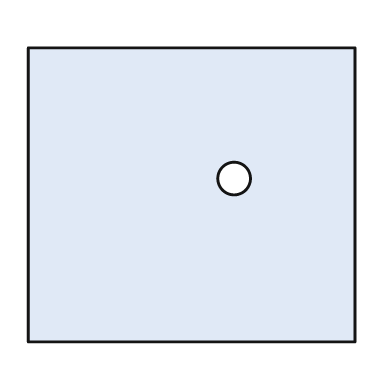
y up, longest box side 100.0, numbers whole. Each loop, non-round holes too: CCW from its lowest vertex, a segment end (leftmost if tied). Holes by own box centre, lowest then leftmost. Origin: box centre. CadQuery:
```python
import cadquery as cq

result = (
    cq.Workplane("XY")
    .moveTo(-50.0, -45.0)
    .lineTo(50.0, -45.0)
    .lineTo(50.0, 45.0)
    .lineTo(-50.0, 45.0)
    .close()
    .moveTo(13.0, 5.0)
    .circle(5.0)
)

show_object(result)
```